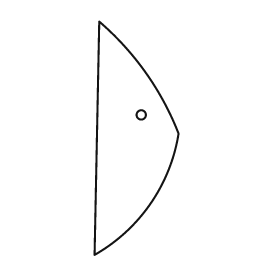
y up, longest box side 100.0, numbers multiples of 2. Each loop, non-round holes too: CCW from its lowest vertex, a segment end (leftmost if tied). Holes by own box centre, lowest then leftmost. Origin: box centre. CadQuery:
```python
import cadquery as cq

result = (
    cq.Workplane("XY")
    .moveTo(-18.0, -50.0)
    .threePointArc((6.0, -28.0), (18.0, 2.0))
    .threePointArc((4.0, 28.0), (-16.0, 50.0))
    .close()
    .moveTo(2.0, 10.0)
    .circle(2.0)
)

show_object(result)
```